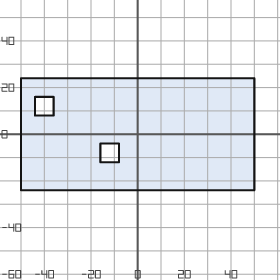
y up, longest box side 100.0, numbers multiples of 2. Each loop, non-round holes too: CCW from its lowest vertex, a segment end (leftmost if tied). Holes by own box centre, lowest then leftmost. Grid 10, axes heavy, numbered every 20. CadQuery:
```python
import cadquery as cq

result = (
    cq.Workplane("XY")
    .moveTo(-50.0, -24.0)
    .lineTo(50.0, -24.0)
    .lineTo(50.0, 24.0)
    .lineTo(-50.0, 24.0)
    .close()
    .moveTo(-16.0, -12.0)
    .lineTo(-8.0, -12.0)
    .lineTo(-8.0, -4.0)
    .lineTo(-16.0, -4.0)
    .close()
    .moveTo(-44.0, 8.0)
    .lineTo(-36.0, 8.0)
    .lineTo(-36.0, 16.0)
    .lineTo(-44.0, 16.0)
    .close()
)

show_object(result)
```